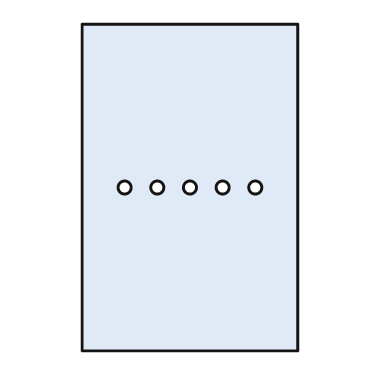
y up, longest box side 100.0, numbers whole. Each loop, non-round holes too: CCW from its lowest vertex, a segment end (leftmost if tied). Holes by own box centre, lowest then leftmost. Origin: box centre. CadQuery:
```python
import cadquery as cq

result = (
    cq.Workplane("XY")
    .moveTo(-33.0, -50.0)
    .lineTo(33.0, -50.0)
    .lineTo(33.0, 50.0)
    .lineTo(-33.0, 50.0)
    .close()
    .moveTo(-20.0, 0.0)
    .circle(2.0)
    .moveTo(-10.0, 0.0)
    .circle(2.0)
    .moveTo(0.0, 0.0)
    .circle(2.0)
    .moveTo(10.0, 0.0)
    .circle(2.0)
    .moveTo(20.0, 0.0)
    .circle(2.0)
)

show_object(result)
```